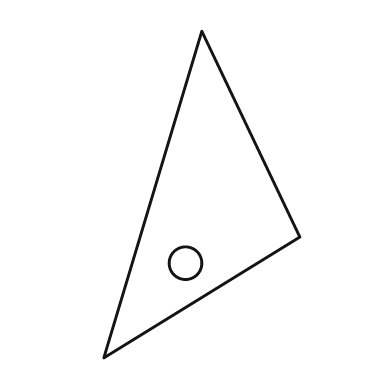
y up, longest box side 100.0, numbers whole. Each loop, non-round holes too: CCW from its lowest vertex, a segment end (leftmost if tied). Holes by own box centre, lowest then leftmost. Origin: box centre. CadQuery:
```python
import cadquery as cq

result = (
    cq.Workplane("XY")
    .moveTo(-30.0, -50.0)
    .lineTo(30.0, -13.0)
    .lineTo(0.0, 50.0)
    .close()
    .moveTo(-5.0, -21.0)
    .circle(5.0)
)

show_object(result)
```